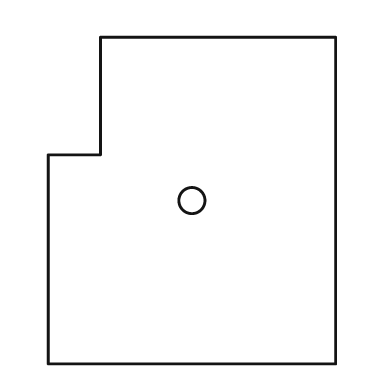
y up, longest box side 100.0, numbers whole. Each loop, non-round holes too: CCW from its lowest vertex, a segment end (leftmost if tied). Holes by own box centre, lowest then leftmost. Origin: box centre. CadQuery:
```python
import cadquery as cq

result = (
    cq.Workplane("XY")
    .moveTo(-44.0, -50.0)
    .lineTo(44.0, -50.0)
    .lineTo(44.0, 50.0)
    .lineTo(-28.0, 50.0)
    .lineTo(-28.0, 14.0)
    .lineTo(-44.0, 14.0)
    .close()
    .moveTo(0.0, 0.0)
    .circle(4.0)
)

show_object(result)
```